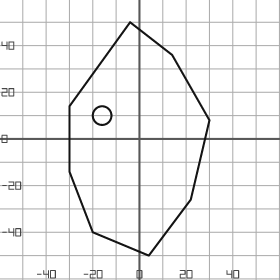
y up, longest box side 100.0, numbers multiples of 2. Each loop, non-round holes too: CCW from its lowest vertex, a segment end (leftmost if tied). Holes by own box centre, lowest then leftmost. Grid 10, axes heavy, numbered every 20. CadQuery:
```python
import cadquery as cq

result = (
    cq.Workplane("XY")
    .moveTo(4.0, -50.0)
    .lineTo(22.0, -26.0)
    .lineTo(30.0, 8.0)
    .lineTo(14.0, 36.0)
    .lineTo(-4.0, 50.0)
    .lineTo(-30.0, 14.0)
    .lineTo(-30.0, -14.0)
    .lineTo(-20.0, -40.0)
    .close()
    .moveTo(-16.0, 10.0)
    .circle(4.0)
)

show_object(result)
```